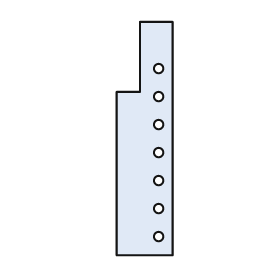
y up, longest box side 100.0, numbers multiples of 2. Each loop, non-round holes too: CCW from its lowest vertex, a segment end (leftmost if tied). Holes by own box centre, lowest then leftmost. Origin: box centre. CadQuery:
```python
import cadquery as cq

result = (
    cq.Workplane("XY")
    .moveTo(-12.0, -50.0)
    .lineTo(12.0, -50.0)
    .lineTo(12.0, 50.0)
    .lineTo(-2.0, 50.0)
    .lineTo(-2.0, 20.0)
    .lineTo(-12.0, 20.0)
    .close()
    .moveTo(6.0, -42.0)
    .circle(2.0)
    .moveTo(6.0, -30.0)
    .circle(2.0)
    .moveTo(6.0, -18.0)
    .circle(2.0)
    .moveTo(6.0, -6.0)
    .circle(2.0)
    .moveTo(6.0, 6.0)
    .circle(2.0)
    .moveTo(6.0, 18.0)
    .circle(2.0)
    .moveTo(6.0, 30.0)
    .circle(2.0)
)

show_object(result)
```